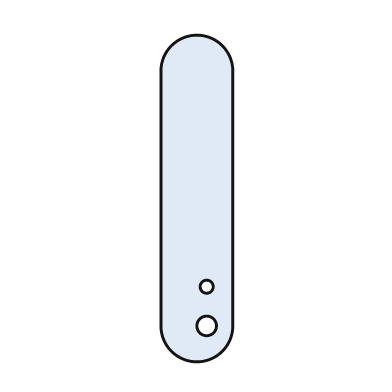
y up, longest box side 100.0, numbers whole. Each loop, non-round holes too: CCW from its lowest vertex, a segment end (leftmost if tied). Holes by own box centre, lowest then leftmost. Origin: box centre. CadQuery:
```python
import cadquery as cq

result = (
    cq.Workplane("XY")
    .moveTo(-11.0, -39.0)
    .threePointArc((0.0, -50.0), (11.0, -39.0))
    .lineTo(11.0, 39.0)
    .threePointArc((0.0, 50.0), (-11.0, 39.0))
    .close()
    .moveTo(3.0, -39.0)
    .circle(3.0)
    .moveTo(3.0, -27.0)
    .circle(2.0)
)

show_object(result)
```